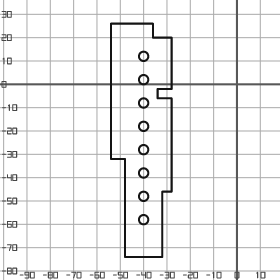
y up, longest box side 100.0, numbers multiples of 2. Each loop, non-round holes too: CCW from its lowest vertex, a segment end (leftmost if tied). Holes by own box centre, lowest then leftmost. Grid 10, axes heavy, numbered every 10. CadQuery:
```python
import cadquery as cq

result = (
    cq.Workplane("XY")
    .moveTo(-48.0, -74.0)
    .lineTo(-32.0, -74.0)
    .lineTo(-32.0, -46.0)
    .lineTo(-28.0, -46.0)
    .lineTo(-28.0, -6.0)
    .lineTo(-34.0, -6.0)
    .lineTo(-34.0, -2.0)
    .lineTo(-28.0, -2.0)
    .lineTo(-28.0, 20.0)
    .lineTo(-36.0, 20.0)
    .lineTo(-36.0, 26.0)
    .lineTo(-54.0, 26.0)
    .lineTo(-54.0, -32.0)
    .lineTo(-48.0, -32.0)
    .close()
    .moveTo(-40.0, -58.0)
    .circle(2.0)
    .moveTo(-40.0, -48.0)
    .circle(2.0)
    .moveTo(-40.0, -38.0)
    .circle(2.0)
    .moveTo(-40.0, -28.0)
    .circle(2.0)
    .moveTo(-40.0, -18.0)
    .circle(2.0)
    .moveTo(-40.0, -8.0)
    .circle(2.0)
    .moveTo(-40.0, 2.0)
    .circle(2.0)
    .moveTo(-40.0, 12.0)
    .circle(2.0)
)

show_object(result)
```